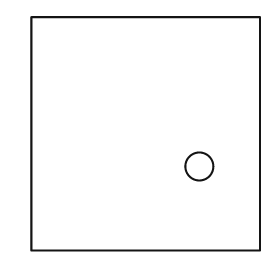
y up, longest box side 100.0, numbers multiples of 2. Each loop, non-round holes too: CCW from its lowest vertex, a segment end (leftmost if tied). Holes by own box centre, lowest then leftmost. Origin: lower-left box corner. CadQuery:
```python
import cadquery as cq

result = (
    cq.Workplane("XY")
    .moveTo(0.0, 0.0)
    .lineTo(98.0, 0.0)
    .lineTo(98.0, 100.0)
    .lineTo(0.0, 100.0)
    .close()
    .moveTo(72.0, 36.0)
    .circle(6.0)
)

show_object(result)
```